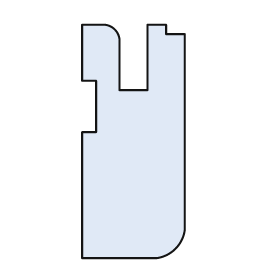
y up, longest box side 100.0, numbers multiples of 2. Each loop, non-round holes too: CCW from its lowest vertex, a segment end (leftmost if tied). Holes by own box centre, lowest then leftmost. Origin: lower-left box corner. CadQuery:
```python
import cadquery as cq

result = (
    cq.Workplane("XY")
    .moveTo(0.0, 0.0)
    .lineTo(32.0, 0.0)
    .threePointArc((40.0, 4.0), (44.0, 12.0))
    .lineTo(44.0, 96.0)
    .lineTo(36.0, 96.0)
    .lineTo(36.0, 100.0)
    .lineTo(28.0, 100.0)
    .lineTo(28.0, 72.0)
    .lineTo(16.0, 72.0)
    .lineTo(16.0, 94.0)
    .threePointArc((14.0, 98.0), (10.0, 100.0))
    .lineTo(0.0, 100.0)
    .lineTo(0.0, 76.0)
    .lineTo(6.0, 76.0)
    .lineTo(6.0, 54.0)
    .lineTo(0.0, 54.0)
    .close()
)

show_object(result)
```